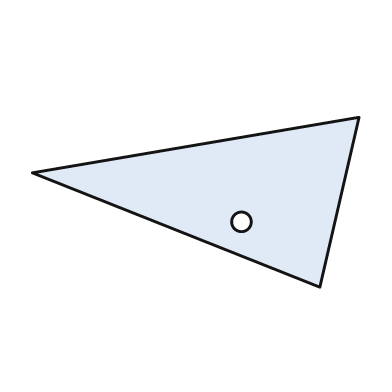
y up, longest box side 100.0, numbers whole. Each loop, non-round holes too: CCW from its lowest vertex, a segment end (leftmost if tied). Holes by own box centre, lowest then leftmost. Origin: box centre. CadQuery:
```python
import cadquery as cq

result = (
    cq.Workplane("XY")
    .moveTo(38.0, -26.0)
    .lineTo(50.0, 26.0)
    .lineTo(-50.0, 9.0)
    .close()
    .moveTo(14.0, -6.0)
    .circle(3.0)
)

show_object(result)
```